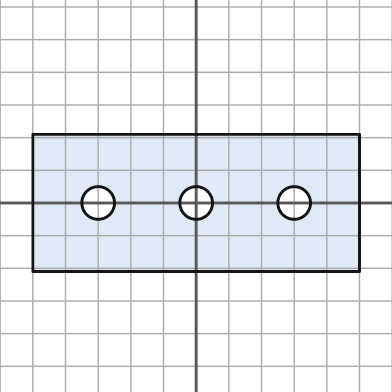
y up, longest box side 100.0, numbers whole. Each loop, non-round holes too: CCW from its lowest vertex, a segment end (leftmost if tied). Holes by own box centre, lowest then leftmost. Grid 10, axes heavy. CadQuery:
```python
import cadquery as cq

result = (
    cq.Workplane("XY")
    .moveTo(-50.0, -21.0)
    .lineTo(50.0, -21.0)
    .lineTo(50.0, 21.0)
    .lineTo(-50.0, 21.0)
    .close()
    .moveTo(-30.0, 0.0)
    .circle(5.0)
    .moveTo(0.0, 0.0)
    .circle(5.0)
    .moveTo(30.0, 0.0)
    .circle(5.0)
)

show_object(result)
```